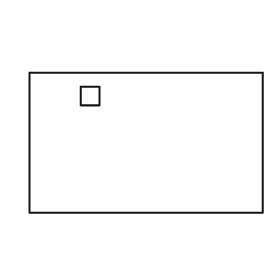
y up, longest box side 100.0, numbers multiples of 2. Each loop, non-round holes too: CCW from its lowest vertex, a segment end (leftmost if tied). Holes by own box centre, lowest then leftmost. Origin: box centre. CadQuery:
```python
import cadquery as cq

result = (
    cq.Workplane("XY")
    .moveTo(-50.0, -30.0)
    .lineTo(50.0, -30.0)
    .lineTo(50.0, 30.0)
    .lineTo(-50.0, 30.0)
    .close()
    .moveTo(-28.0, 16.0)
    .lineTo(-20.0, 16.0)
    .lineTo(-20.0, 24.0)
    .lineTo(-28.0, 24.0)
    .close()
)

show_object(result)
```